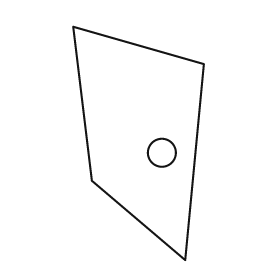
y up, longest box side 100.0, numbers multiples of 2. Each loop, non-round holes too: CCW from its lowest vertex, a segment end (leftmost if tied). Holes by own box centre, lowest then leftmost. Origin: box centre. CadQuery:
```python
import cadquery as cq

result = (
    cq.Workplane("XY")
    .moveTo(20.0, -50.0)
    .lineTo(28.0, 34.0)
    .lineTo(-28.0, 50.0)
    .lineTo(-20.0, -16.0)
    .close()
    .moveTo(10.0, -4.0)
    .circle(6.0)
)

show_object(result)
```